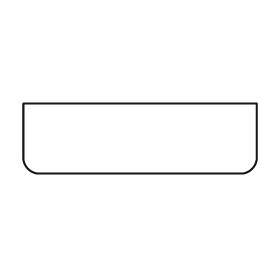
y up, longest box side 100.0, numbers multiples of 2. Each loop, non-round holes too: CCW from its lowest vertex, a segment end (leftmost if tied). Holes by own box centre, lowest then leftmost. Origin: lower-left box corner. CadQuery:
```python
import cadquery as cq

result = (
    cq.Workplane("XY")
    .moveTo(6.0, 0.0)
    .lineTo(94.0, 0.0)
    .threePointArc((98.0, 2.0), (100.0, 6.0))
    .lineTo(100.0, 30.0)
    .lineTo(0.0, 30.0)
    .lineTo(0.0, 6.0)
    .threePointArc((2.0, 2.0), (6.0, 0.0))
    .close()
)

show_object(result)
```